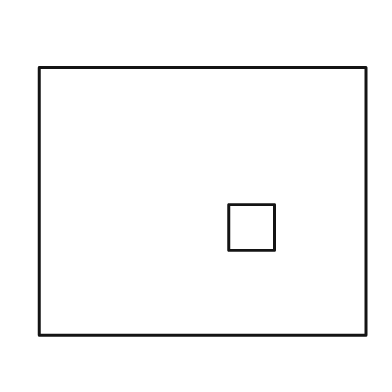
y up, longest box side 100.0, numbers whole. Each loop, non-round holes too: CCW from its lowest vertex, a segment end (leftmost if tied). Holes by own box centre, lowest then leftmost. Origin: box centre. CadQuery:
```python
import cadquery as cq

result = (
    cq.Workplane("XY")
    .moveTo(-50.0, -41.0)
    .lineTo(50.0, -41.0)
    .lineTo(50.0, 41.0)
    .lineTo(-50.0, 41.0)
    .close()
    .moveTo(8.0, -15.0)
    .lineTo(22.0, -15.0)
    .lineTo(22.0, -1.0)
    .lineTo(8.0, -1.0)
    .close()
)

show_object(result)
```